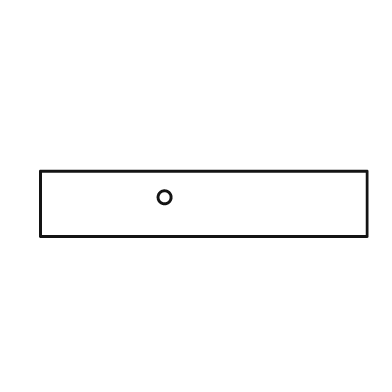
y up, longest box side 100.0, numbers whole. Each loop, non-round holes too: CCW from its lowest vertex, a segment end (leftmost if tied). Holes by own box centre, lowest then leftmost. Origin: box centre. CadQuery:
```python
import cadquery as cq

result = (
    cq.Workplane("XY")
    .moveTo(-50.0, -10.0)
    .lineTo(50.0, -10.0)
    .lineTo(50.0, 10.0)
    .lineTo(-50.0, 10.0)
    .close()
    .moveTo(-12.0, 2.0)
    .circle(2.0)
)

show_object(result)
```